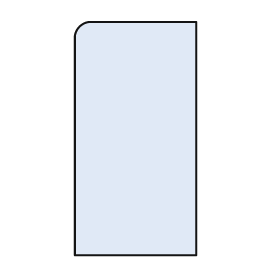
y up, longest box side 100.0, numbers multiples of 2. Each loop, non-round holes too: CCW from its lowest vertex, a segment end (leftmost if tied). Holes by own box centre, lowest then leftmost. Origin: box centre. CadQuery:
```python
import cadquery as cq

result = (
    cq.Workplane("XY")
    .moveTo(-26.0, -50.0)
    .lineTo(26.0, -50.0)
    .lineTo(26.0, 50.0)
    .lineTo(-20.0, 50.0)
    .threePointArc((-24.0, 48.0), (-26.0, 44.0))
    .close()
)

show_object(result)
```